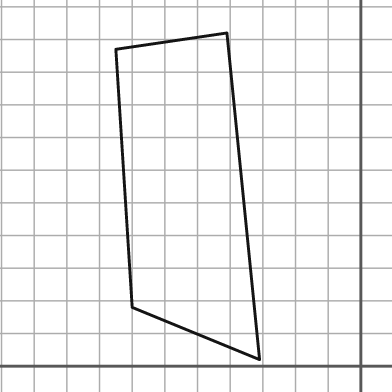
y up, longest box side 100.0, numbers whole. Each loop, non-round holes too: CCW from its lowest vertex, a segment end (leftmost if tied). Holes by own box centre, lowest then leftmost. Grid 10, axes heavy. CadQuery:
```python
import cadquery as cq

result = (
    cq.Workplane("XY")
    .moveTo(-31.0, 2.0)
    .lineTo(-41.0, 102.0)
    .lineTo(-75.0, 97.0)
    .lineTo(-70.0, 18.0)
    .close()
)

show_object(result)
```